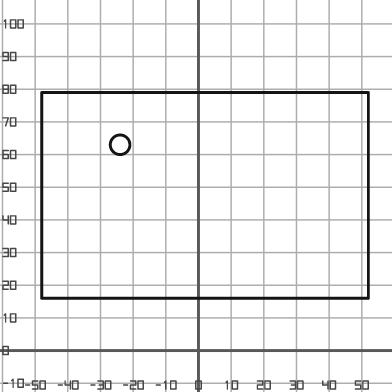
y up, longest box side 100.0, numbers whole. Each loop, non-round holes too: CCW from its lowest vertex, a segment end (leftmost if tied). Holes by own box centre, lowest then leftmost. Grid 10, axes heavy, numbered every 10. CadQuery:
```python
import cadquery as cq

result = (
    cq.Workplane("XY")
    .moveTo(-48.0, 16.0)
    .lineTo(52.0, 16.0)
    .lineTo(52.0, 79.0)
    .lineTo(-48.0, 79.0)
    .close()
    .moveTo(-24.0, 63.0)
    .circle(3.0)
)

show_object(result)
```